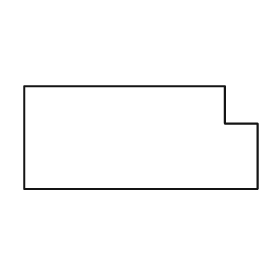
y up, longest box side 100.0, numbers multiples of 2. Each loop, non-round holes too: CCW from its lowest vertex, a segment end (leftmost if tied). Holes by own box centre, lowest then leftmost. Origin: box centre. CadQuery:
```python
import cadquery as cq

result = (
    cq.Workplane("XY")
    .moveTo(-50.0, -22.0)
    .lineTo(50.0, -22.0)
    .lineTo(50.0, 6.0)
    .lineTo(36.0, 6.0)
    .lineTo(36.0, 22.0)
    .lineTo(-50.0, 22.0)
    .close()
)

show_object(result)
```